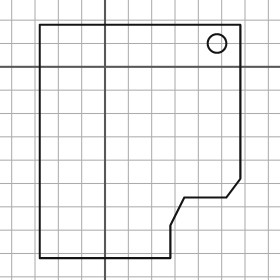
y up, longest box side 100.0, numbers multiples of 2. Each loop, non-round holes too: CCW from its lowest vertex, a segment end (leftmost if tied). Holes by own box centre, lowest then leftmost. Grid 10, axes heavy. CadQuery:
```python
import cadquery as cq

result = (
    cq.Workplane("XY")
    .moveTo(-28.0, -82.0)
    .lineTo(28.0, -82.0)
    .lineTo(28.0, -68.0)
    .lineTo(34.0, -56.0)
    .lineTo(52.0, -56.0)
    .lineTo(58.0, -48.0)
    .lineTo(58.0, 18.0)
    .lineTo(-28.0, 18.0)
    .close()
    .moveTo(48.0, 10.0)
    .circle(4.0)
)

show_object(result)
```